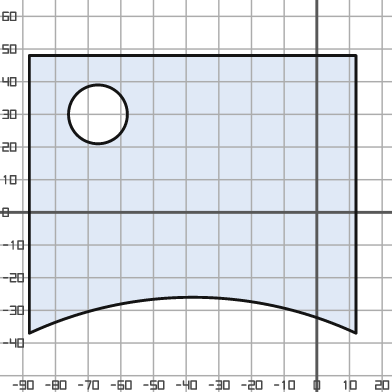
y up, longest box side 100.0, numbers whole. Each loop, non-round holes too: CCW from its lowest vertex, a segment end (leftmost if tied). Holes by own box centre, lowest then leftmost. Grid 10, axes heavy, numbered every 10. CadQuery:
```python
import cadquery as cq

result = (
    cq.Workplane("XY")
    .moveTo(-88.0, -37.0)
    .threePointArc((-38.0, -26.0), (12.0, -37.0))
    .lineTo(12.0, 48.0)
    .lineTo(-88.0, 48.0)
    .close()
    .moveTo(-67.0, 30.0)
    .circle(9.0)
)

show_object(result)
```